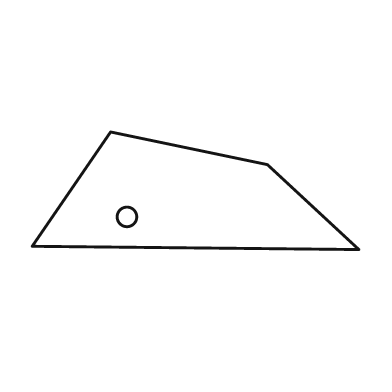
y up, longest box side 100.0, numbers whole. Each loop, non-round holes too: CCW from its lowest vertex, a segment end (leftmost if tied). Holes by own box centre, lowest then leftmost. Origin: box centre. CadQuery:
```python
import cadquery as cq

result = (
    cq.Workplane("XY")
    .moveTo(50.0, -18.0)
    .lineTo(22.0, 8.0)
    .lineTo(-26.0, 18.0)
    .lineTo(-50.0, -17.0)
    .close()
    .moveTo(-21.0, -8.0)
    .circle(3.0)
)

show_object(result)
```